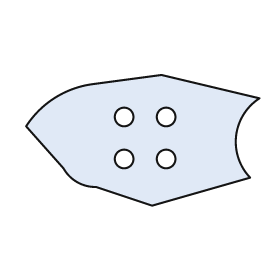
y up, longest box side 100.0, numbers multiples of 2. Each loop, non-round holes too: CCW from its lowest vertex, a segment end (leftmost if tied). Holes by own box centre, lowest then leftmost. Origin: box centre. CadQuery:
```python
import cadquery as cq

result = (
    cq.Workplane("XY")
    .moveTo(4.0, -28.0)
    .lineTo(46.0, -16.0)
    .threePointArc((40.0, 2.0), (50.0, 18.0))
    .lineTo(8.0, 28.0)
    .lineTo(-22.0, 24.0)
    .threePointArc((-38.0, 18.0), (-50.0, 6.0))
    .lineTo(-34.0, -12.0)
    .threePointArc((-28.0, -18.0), (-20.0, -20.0))
    .close()
    .moveTo(-8.0, -8.0)
    .circle(4.0)
    .moveTo(10.0, -8.0)
    .circle(4.0)
    .moveTo(-8.0, 10.0)
    .circle(4.0)
    .moveTo(10.0, 10.0)
    .circle(4.0)
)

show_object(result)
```